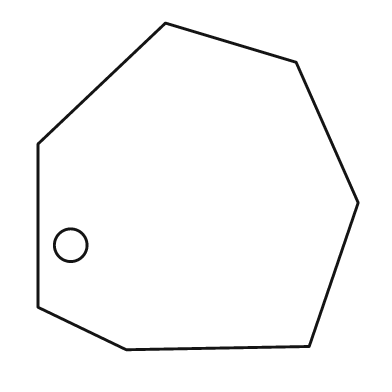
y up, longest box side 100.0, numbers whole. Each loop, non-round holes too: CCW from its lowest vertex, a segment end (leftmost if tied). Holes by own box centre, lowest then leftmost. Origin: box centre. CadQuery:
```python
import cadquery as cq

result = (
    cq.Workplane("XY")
    .moveTo(-22.0, -50.0)
    .lineTo(34.0, -49.0)
    .lineTo(49.0, -5.0)
    .lineTo(30.0, 38.0)
    .lineTo(-10.0, 50.0)
    .lineTo(-49.0, 13.0)
    .lineTo(-49.0, -37.0)
    .close()
    .moveTo(-39.0, -18.0)
    .circle(5.0)
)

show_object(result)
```